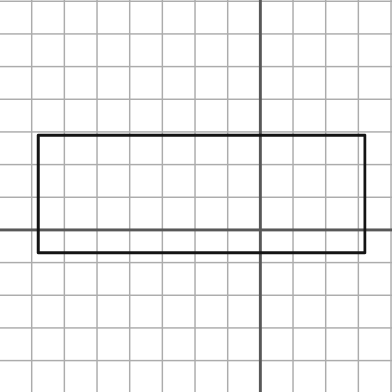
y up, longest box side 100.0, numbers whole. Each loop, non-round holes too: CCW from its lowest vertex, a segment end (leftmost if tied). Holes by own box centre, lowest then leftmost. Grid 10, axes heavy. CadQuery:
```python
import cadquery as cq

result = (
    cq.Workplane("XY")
    .moveTo(-68.0, -7.0)
    .lineTo(32.0, -7.0)
    .lineTo(32.0, 29.0)
    .lineTo(-68.0, 29.0)
    .close()
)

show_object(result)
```